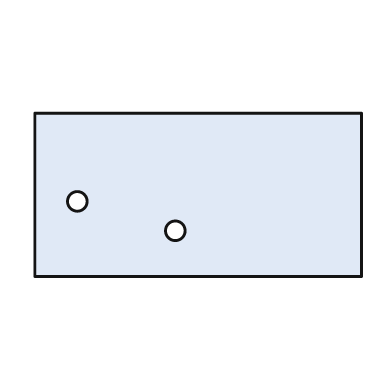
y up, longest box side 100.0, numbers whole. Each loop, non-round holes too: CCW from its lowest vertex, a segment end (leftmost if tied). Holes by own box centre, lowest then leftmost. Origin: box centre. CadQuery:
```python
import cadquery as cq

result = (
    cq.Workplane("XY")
    .moveTo(-50.0, -25.0)
    .lineTo(50.0, -25.0)
    .lineTo(50.0, 25.0)
    .lineTo(-50.0, 25.0)
    .close()
    .moveTo(-7.0, -11.0)
    .circle(3.0)
    .moveTo(-37.0, -2.0)
    .circle(3.0)
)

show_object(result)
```